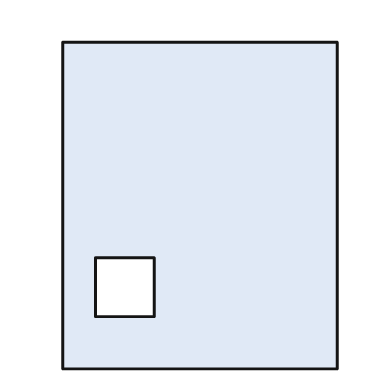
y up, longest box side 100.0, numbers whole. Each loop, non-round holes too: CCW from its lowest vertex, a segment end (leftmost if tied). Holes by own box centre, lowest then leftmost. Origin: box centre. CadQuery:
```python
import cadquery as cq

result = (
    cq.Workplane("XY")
    .moveTo(-42.0, -50.0)
    .lineTo(42.0, -50.0)
    .lineTo(42.0, 50.0)
    .lineTo(-42.0, 50.0)
    .close()
    .moveTo(-32.0, -34.0)
    .lineTo(-14.0, -34.0)
    .lineTo(-14.0, -16.0)
    .lineTo(-32.0, -16.0)
    .close()
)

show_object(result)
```